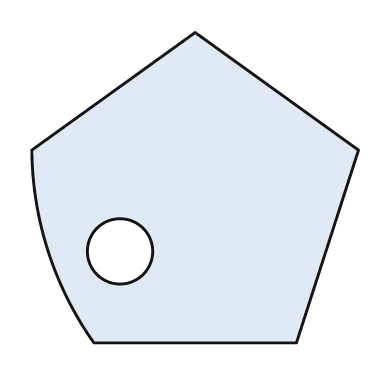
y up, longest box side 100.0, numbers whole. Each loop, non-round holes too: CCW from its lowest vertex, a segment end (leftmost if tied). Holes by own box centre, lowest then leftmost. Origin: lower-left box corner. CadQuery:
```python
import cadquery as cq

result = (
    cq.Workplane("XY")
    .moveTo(19.0, 0.0)
    .lineTo(81.0, 0.0)
    .lineTo(100.0, 59.0)
    .lineTo(50.0, 95.0)
    .lineTo(0.0, 59.0)
    .threePointArc((5.0, 28.0), (19.0, 0.0))
    .close()
    .moveTo(27.0, 28.0)
    .circle(10.0)
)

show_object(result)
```